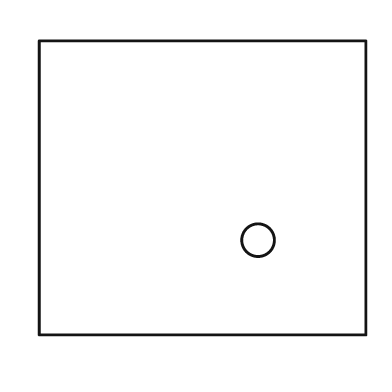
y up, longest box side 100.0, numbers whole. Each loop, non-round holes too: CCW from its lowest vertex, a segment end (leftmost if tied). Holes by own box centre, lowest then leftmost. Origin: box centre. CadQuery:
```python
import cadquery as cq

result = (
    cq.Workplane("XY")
    .moveTo(-50.0, -45.0)
    .lineTo(50.0, -45.0)
    .lineTo(50.0, 45.0)
    .lineTo(-50.0, 45.0)
    .close()
    .moveTo(17.0, -16.0)
    .circle(5.0)
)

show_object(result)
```